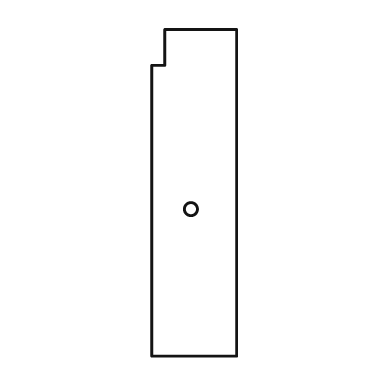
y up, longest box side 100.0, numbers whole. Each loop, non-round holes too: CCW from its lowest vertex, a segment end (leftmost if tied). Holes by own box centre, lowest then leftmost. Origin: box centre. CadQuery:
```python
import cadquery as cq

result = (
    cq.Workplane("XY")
    .moveTo(-13.0, -50.0)
    .lineTo(13.0, -50.0)
    .lineTo(13.0, 50.0)
    .lineTo(-9.0, 50.0)
    .lineTo(-9.0, 39.0)
    .lineTo(-13.0, 39.0)
    .close()
    .moveTo(-1.0, -5.0)
    .circle(2.0)
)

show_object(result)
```